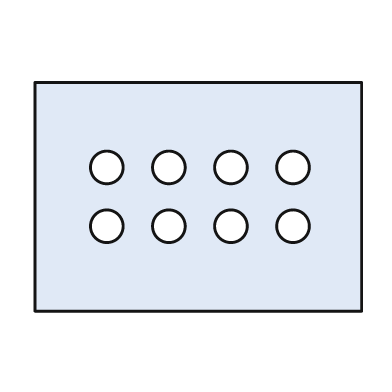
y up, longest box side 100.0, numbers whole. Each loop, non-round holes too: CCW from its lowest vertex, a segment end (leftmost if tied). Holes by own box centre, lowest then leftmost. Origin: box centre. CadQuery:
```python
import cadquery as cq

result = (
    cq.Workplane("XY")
    .moveTo(-50.0, -35.0)
    .lineTo(50.0, -35.0)
    .lineTo(50.0, 35.0)
    .lineTo(-50.0, 35.0)
    .close()
    .moveTo(-28.0, -9.0)
    .circle(5.0)
    .moveTo(-9.0, -9.0)
    .circle(5.0)
    .moveTo(10.0, -9.0)
    .circle(5.0)
    .moveTo(29.0, -9.0)
    .circle(5.0)
    .moveTo(-28.0, 9.0)
    .circle(5.0)
    .moveTo(-9.0, 9.0)
    .circle(5.0)
    .moveTo(10.0, 9.0)
    .circle(5.0)
    .moveTo(29.0, 9.0)
    .circle(5.0)
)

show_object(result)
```